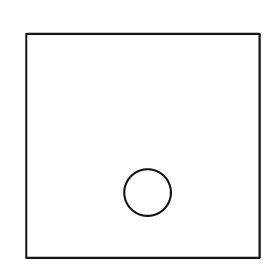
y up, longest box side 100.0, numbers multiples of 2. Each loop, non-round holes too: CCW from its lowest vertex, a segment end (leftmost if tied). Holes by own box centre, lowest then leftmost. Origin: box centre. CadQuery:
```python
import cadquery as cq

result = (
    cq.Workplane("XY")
    .moveTo(-50.0, -48.0)
    .lineTo(50.0, -48.0)
    .lineTo(50.0, 48.0)
    .lineTo(-50.0, 48.0)
    .close()
    .moveTo(2.0, -20.0)
    .circle(10.0)
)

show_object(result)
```